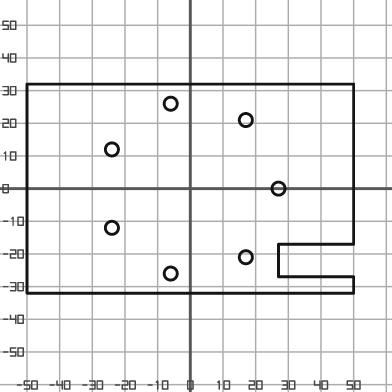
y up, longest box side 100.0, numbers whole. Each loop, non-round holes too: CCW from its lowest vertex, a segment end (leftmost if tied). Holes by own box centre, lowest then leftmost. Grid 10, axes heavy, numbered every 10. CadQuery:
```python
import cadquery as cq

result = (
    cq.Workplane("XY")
    .moveTo(-50.0, -32.0)
    .lineTo(50.0, -32.0)
    .lineTo(50.0, -27.0)
    .lineTo(27.0, -27.0)
    .lineTo(27.0, -17.0)
    .lineTo(50.0, -17.0)
    .lineTo(50.0, 32.0)
    .lineTo(-50.0, 32.0)
    .close()
    .moveTo(-6.0, -26.0)
    .circle(2.0)
    .moveTo(17.0, -21.0)
    .circle(2.0)
    .moveTo(-24.0, -12.0)
    .circle(2.0)
    .moveTo(27.0, 0.0)
    .circle(2.0)
    .moveTo(-24.0, 12.0)
    .circle(2.0)
    .moveTo(17.0, 21.0)
    .circle(2.0)
    .moveTo(-6.0, 26.0)
    .circle(2.0)
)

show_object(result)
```